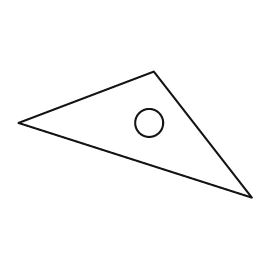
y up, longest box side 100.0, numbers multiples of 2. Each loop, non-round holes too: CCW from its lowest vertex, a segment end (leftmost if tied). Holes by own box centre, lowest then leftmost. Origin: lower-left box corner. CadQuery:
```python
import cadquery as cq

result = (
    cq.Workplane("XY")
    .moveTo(100.0, 0.0)
    .lineTo(58.0, 54.0)
    .lineTo(0.0, 32.0)
    .close()
    .moveTo(56.0, 32.0)
    .circle(6.0)
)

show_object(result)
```